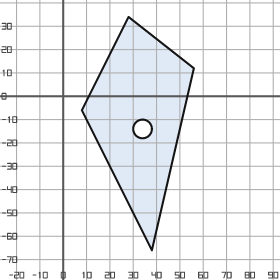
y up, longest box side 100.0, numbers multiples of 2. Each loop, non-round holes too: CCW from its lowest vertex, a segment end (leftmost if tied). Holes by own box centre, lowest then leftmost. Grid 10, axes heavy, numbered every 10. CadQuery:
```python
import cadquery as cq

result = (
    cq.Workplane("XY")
    .moveTo(38.0, -66.0)
    .lineTo(56.0, 12.0)
    .lineTo(28.0, 34.0)
    .lineTo(8.0, -6.0)
    .close()
    .moveTo(34.0, -14.0)
    .circle(4.0)
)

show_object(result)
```